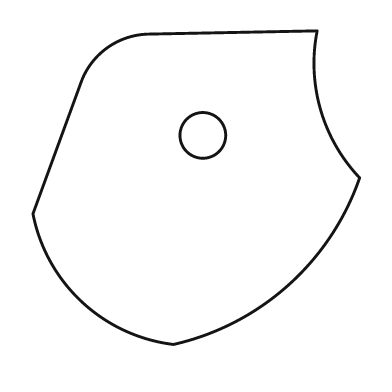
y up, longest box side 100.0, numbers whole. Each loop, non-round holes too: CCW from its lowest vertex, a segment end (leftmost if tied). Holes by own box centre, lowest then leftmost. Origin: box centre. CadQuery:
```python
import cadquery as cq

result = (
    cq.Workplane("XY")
    .moveTo(-7.0, -48.0)
    .threePointArc((28.0, -30.0), (50.0, 3.0))
    .threePointArc((38.0, 24.0), (37.0, 48.0))
    .lineTo(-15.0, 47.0)
    .threePointArc((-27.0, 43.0), (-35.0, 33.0))
    .lineTo(-50.0, -8.0)
    .threePointArc((-35.0, -35.0), (-7.0, -48.0))
    .close()
    .moveTo(2.0, 16.0)
    .circle(7.0)
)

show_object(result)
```